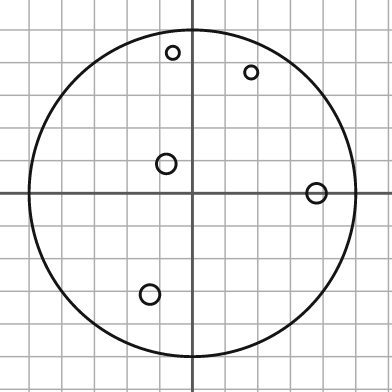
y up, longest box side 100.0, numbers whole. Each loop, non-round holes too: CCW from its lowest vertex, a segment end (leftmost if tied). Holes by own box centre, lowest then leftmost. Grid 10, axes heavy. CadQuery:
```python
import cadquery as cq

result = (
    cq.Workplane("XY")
    .moveTo(0.0, 0.0)
    .circle(50.0)
    .moveTo(-13.0, -31.0)
    .circle(3.0)
    .moveTo(38.0, 0.0)
    .circle(3.0)
    .moveTo(-8.0, 9.0)
    .circle(3.0)
    .moveTo(18.0, 37.0)
    .circle(2.0)
    .moveTo(-6.0, 43.0)
    .circle(2.0)
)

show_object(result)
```